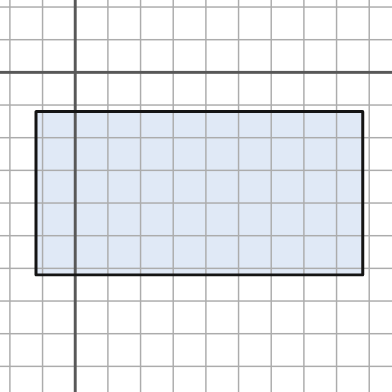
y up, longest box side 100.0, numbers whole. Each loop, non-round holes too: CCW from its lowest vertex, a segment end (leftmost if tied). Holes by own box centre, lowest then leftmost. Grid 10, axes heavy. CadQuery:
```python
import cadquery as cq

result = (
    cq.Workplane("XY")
    .moveTo(-12.0, -62.0)
    .lineTo(88.0, -62.0)
    .lineTo(88.0, -12.0)
    .lineTo(-12.0, -12.0)
    .close()
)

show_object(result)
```